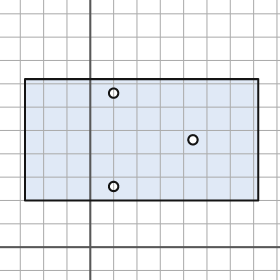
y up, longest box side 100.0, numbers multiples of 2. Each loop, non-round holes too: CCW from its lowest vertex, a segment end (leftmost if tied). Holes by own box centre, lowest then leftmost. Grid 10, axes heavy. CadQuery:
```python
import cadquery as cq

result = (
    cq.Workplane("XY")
    .moveTo(-28.0, 20.0)
    .lineTo(72.0, 20.0)
    .lineTo(72.0, 72.0)
    .lineTo(-28.0, 72.0)
    .close()
    .moveTo(10.0, 26.0)
    .circle(2.0)
    .moveTo(44.0, 46.0)
    .circle(2.0)
    .moveTo(10.0, 66.0)
    .circle(2.0)
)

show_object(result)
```